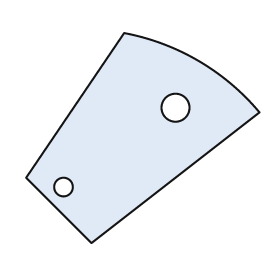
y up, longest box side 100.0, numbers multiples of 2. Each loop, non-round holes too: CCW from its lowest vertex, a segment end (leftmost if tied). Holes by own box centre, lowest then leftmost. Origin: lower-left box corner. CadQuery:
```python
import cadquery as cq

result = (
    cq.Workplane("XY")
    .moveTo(28.0, 0.0)
    .lineTo(100.0, 56.0)
    .threePointArc((74.0, 78.0), (42.0, 90.0))
    .lineTo(0.0, 28.0)
    .close()
    .moveTo(16.0, 24.0)
    .circle(4.0)
    .moveTo(64.0, 58.0)
    .circle(6.0)
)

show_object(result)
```